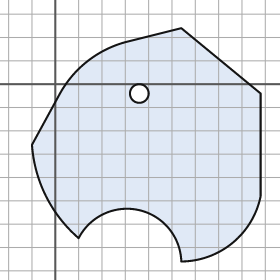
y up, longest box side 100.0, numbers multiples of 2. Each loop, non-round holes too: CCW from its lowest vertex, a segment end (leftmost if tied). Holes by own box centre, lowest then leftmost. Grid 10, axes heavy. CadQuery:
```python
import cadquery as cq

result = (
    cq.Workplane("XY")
    .moveTo(54.0, -76.0)
    .threePointArc((76.0, -68.0), (88.0, -48.0))
    .lineTo(88.0, -4.0)
    .lineTo(54.0, 24.0)
    .lineTo(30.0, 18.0)
    .threePointArc((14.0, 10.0), (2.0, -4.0))
    .lineTo(-10.0, -26.0)
    .threePointArc((-4.0, -48.0), (10.0, -66.0))
    .threePointArc((36.0, -54.0), (54.0, -76.0))
    .close()
    .moveTo(36.0, -4.0)
    .circle(4.0)
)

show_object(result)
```